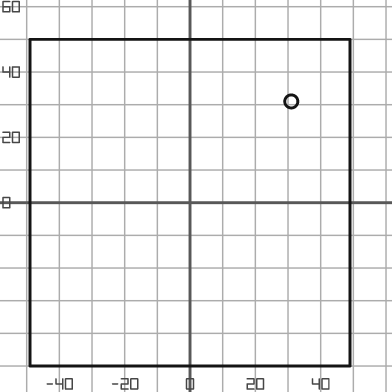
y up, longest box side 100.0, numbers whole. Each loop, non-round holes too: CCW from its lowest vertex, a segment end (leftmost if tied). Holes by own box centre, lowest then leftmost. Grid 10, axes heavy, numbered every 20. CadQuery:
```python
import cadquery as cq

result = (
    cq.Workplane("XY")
    .moveTo(-49.0, -50.0)
    .lineTo(49.0, -50.0)
    .lineTo(49.0, 50.0)
    .lineTo(-49.0, 50.0)
    .close()
    .moveTo(31.0, 31.0)
    .circle(2.0)
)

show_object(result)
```